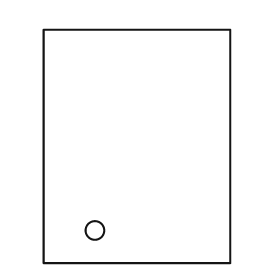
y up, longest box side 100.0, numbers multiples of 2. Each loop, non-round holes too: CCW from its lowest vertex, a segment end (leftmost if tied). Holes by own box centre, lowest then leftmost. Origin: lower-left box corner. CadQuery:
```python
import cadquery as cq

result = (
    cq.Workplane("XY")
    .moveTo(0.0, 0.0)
    .lineTo(80.0, 0.0)
    .lineTo(80.0, 100.0)
    .lineTo(0.0, 100.0)
    .close()
    .moveTo(22.0, 14.0)
    .circle(4.0)
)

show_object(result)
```